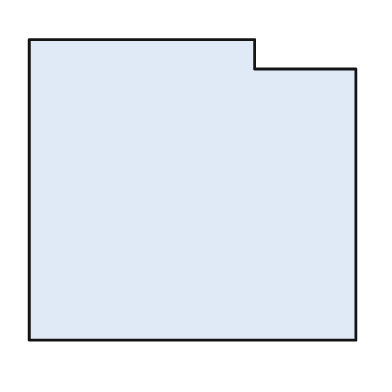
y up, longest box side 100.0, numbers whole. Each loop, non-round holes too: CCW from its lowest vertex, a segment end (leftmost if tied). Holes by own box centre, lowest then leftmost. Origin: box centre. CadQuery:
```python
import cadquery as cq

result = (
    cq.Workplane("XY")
    .moveTo(-50.0, -46.0)
    .lineTo(50.0, -46.0)
    .lineTo(50.0, 37.0)
    .lineTo(19.0, 37.0)
    .lineTo(19.0, 46.0)
    .lineTo(-50.0, 46.0)
    .close()
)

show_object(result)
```